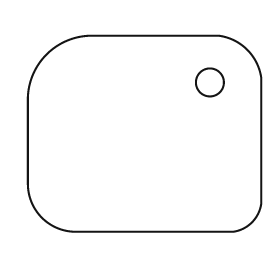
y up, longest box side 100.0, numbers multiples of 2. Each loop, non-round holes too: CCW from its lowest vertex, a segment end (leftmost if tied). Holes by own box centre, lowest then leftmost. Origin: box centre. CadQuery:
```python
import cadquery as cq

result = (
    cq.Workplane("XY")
    .moveTo(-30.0, -42.0)
    .lineTo(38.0, -42.0)
    .threePointArc((46.0, -38.0), (50.0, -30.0))
    .lineTo(50.0, 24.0)
    .threePointArc((44.0, 36.0), (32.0, 42.0))
    .lineTo(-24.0, 42.0)
    .threePointArc((-42.0, 34.0), (-50.0, 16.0))
    .lineTo(-50.0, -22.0)
    .threePointArc((-44.0, -36.0), (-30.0, -42.0))
    .close()
    .moveTo(28.0, 22.0)
    .circle(6.0)
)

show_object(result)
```